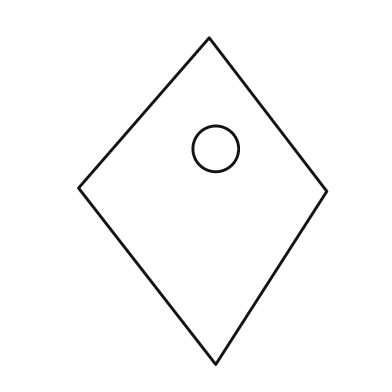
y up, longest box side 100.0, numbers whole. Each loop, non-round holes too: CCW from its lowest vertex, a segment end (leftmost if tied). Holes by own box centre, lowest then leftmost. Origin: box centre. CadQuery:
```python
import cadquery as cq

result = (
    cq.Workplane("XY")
    .moveTo(4.0, -50.0)
    .lineTo(38.0, 3.0)
    .lineTo(2.0, 50.0)
    .lineTo(-38.0, 4.0)
    .close()
    .moveTo(4.0, 16.0)
    .circle(7.0)
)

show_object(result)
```